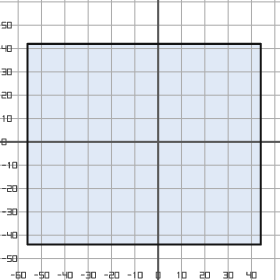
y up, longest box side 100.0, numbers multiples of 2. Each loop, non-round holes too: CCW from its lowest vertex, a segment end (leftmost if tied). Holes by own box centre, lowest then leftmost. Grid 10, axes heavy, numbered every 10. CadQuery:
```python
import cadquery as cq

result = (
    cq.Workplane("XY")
    .moveTo(-56.0, -44.0)
    .lineTo(44.0, -44.0)
    .lineTo(44.0, 42.0)
    .lineTo(-56.0, 42.0)
    .close()
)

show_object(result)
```